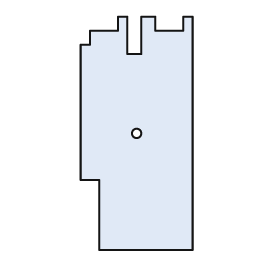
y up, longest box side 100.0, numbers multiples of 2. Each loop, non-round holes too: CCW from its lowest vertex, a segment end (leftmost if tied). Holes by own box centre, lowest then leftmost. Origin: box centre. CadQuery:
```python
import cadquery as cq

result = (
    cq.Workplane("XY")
    .moveTo(-16.0, -50.0)
    .lineTo(24.0, -50.0)
    .lineTo(24.0, 50.0)
    .lineTo(20.0, 50.0)
    .lineTo(20.0, 44.0)
    .lineTo(8.0, 44.0)
    .lineTo(8.0, 50.0)
    .lineTo(2.0, 50.0)
    .lineTo(2.0, 34.0)
    .lineTo(-4.0, 34.0)
    .lineTo(-4.0, 50.0)
    .lineTo(-8.0, 50.0)
    .lineTo(-8.0, 44.0)
    .lineTo(-20.0, 44.0)
    .lineTo(-20.0, 38.0)
    .lineTo(-24.0, 38.0)
    .lineTo(-24.0, -20.0)
    .lineTo(-16.0, -20.0)
    .close()
    .moveTo(0.0, 0.0)
    .circle(2.0)
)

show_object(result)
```